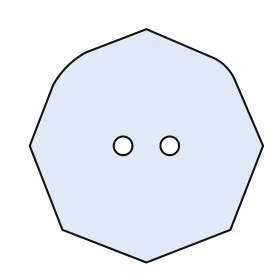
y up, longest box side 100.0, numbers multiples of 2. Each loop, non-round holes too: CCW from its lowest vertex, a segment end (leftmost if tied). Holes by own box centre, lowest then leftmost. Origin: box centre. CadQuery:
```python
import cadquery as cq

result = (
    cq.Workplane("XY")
    .moveTo(0.0, -50.0)
    .lineTo(36.0, -36.0)
    .lineTo(50.0, 0.0)
    .lineTo(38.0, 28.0)
    .threePointArc((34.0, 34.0), (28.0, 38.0))
    .lineTo(0.0, 50.0)
    .lineTo(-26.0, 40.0)
    .threePointArc((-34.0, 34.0), (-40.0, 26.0))
    .lineTo(-50.0, 0.0)
    .lineTo(-36.0, -36.0)
    .close()
    .moveTo(-10.0, 0.0)
    .circle(4.0)
    .moveTo(10.0, 0.0)
    .circle(4.0)
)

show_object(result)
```